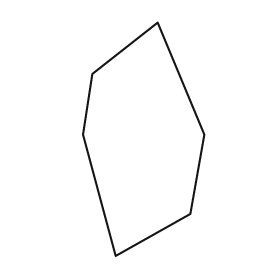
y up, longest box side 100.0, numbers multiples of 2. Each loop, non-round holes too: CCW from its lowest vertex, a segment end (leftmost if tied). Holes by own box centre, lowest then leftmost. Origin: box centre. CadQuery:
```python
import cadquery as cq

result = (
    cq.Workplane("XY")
    .moveTo(-12.0, -50.0)
    .lineTo(20.0, -32.0)
    .lineTo(26.0, 2.0)
    .lineTo(6.0, 50.0)
    .lineTo(-22.0, 28.0)
    .lineTo(-26.0, 2.0)
    .close()
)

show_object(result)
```